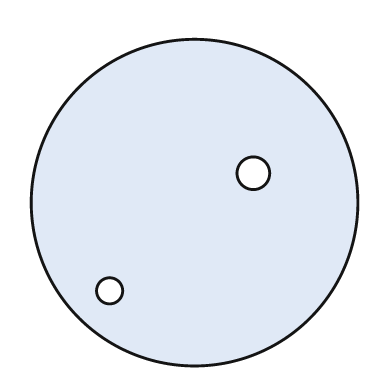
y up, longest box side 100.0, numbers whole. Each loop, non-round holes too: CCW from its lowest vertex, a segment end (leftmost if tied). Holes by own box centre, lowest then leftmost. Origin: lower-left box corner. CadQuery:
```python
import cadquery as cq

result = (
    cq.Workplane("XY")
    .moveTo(50.0, 50.0)
    .circle(50.0)
    .moveTo(24.0, 23.0)
    .circle(4.0)
    .moveTo(68.0, 59.0)
    .circle(5.0)
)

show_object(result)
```